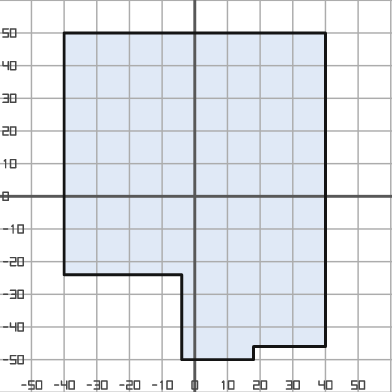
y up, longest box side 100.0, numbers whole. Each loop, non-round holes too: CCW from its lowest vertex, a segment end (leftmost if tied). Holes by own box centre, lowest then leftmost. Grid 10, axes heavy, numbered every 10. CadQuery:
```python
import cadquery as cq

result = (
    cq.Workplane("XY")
    .moveTo(-4.0, -50.0)
    .lineTo(18.0, -50.0)
    .lineTo(18.0, -46.0)
    .lineTo(40.0, -46.0)
    .lineTo(40.0, 50.0)
    .lineTo(-40.0, 50.0)
    .lineTo(-40.0, -24.0)
    .lineTo(-4.0, -24.0)
    .close()
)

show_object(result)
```